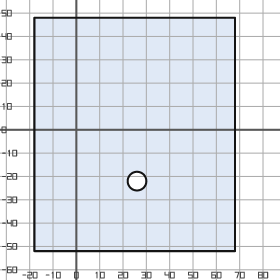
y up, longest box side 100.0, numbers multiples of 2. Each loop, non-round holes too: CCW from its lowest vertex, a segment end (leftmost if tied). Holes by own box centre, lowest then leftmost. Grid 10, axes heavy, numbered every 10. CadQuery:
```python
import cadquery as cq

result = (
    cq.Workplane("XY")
    .moveTo(-18.0, -52.0)
    .lineTo(68.0, -52.0)
    .lineTo(68.0, 48.0)
    .lineTo(-18.0, 48.0)
    .close()
    .moveTo(26.0, -22.0)
    .circle(4.0)
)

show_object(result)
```